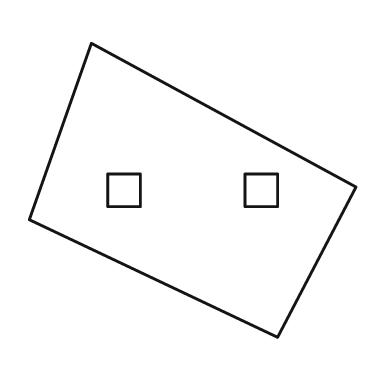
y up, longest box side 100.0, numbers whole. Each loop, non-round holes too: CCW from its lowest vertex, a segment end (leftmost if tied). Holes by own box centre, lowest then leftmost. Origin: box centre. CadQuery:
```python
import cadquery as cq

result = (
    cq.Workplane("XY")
    .moveTo(26.0, -45.0)
    .lineTo(50.0, 1.0)
    .lineTo(-31.0, 45.0)
    .lineTo(-50.0, -9.0)
    .close()
    .moveTo(-26.0, -5.0)
    .lineTo(-16.0, -5.0)
    .lineTo(-16.0, 5.0)
    .lineTo(-26.0, 5.0)
    .close()
    .moveTo(16.0, -5.0)
    .lineTo(26.0, -5.0)
    .lineTo(26.0, 5.0)
    .lineTo(16.0, 5.0)
    .close()
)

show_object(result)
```